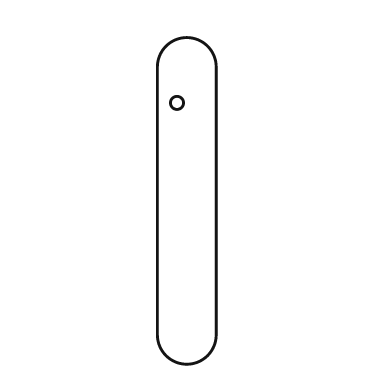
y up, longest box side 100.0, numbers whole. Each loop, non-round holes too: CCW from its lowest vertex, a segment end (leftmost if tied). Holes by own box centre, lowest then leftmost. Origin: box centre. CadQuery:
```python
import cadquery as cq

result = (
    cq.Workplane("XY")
    .moveTo(-9.0, -41.0)
    .threePointArc((0.0, -50.0), (9.0, -41.0))
    .lineTo(9.0, 41.0)
    .threePointArc((0.0, 50.0), (-9.0, 41.0))
    .close()
    .moveTo(-3.0, 30.0)
    .circle(2.0)
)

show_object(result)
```